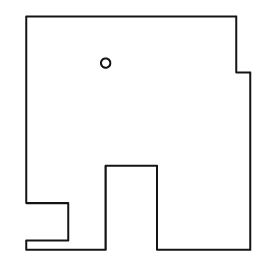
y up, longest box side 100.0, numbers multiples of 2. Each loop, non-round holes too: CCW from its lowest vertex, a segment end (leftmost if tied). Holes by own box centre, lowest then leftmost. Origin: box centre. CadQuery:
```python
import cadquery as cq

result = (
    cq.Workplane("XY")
    .moveTo(-48.0, -50.0)
    .lineTo(-14.0, -50.0)
    .lineTo(-14.0, -14.0)
    .lineTo(8.0, -14.0)
    .lineTo(8.0, -50.0)
    .lineTo(48.0, -50.0)
    .lineTo(48.0, 26.0)
    .lineTo(42.0, 26.0)
    .lineTo(42.0, 50.0)
    .lineTo(-48.0, 50.0)
    .lineTo(-48.0, -30.0)
    .lineTo(-30.0, -30.0)
    .lineTo(-30.0, -46.0)
    .lineTo(-48.0, -46.0)
    .close()
    .moveTo(-14.0, 30.0)
    .circle(2.0)
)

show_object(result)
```